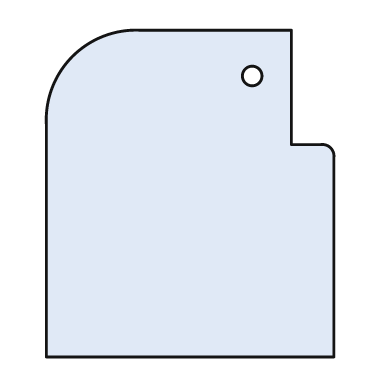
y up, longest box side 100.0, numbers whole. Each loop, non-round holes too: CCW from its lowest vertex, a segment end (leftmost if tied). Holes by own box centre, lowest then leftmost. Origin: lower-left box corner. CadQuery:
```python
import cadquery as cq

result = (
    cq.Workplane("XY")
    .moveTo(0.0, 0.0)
    .lineTo(88.0, 0.0)
    .lineTo(88.0, 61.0)
    .threePointArc((87.0, 64.0), (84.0, 65.0))
    .lineTo(75.0, 65.0)
    .lineTo(75.0, 100.0)
    .lineTo(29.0, 100.0)
    .threePointArc((8.0, 92.0), (0.0, 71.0))
    .close()
    .moveTo(63.0, 86.0)
    .circle(3.0)
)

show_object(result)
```